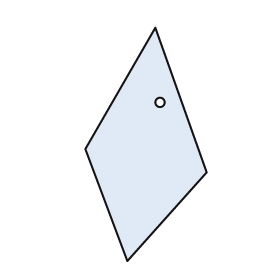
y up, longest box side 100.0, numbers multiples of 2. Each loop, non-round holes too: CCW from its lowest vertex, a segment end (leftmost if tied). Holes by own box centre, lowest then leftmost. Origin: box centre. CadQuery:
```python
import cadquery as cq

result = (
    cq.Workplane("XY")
    .moveTo(-8.0, -50.0)
    .lineTo(26.0, -12.0)
    .lineTo(4.0, 50.0)
    .lineTo(-26.0, -2.0)
    .close()
    .moveTo(6.0, 18.0)
    .circle(2.0)
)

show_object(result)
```